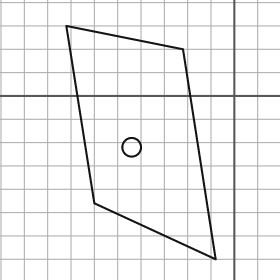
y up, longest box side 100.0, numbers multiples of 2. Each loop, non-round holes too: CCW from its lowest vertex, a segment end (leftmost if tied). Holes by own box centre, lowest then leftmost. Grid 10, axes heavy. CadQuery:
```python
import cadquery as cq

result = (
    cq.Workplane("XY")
    .moveTo(-8.0, -70.0)
    .lineTo(-22.0, 20.0)
    .lineTo(-72.0, 30.0)
    .lineTo(-60.0, -46.0)
    .close()
    .moveTo(-44.0, -22.0)
    .circle(4.0)
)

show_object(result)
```